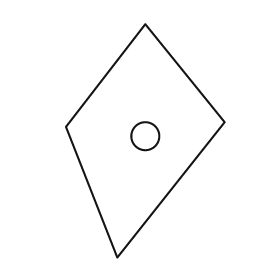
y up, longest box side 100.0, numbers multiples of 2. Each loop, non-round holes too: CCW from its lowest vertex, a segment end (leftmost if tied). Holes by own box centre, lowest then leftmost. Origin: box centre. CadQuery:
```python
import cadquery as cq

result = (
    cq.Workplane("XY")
    .moveTo(-12.0, -50.0)
    .lineTo(34.0, 8.0)
    .lineTo(0.0, 50.0)
    .lineTo(-34.0, 6.0)
    .close()
    .moveTo(0.0, 2.0)
    .circle(6.0)
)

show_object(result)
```